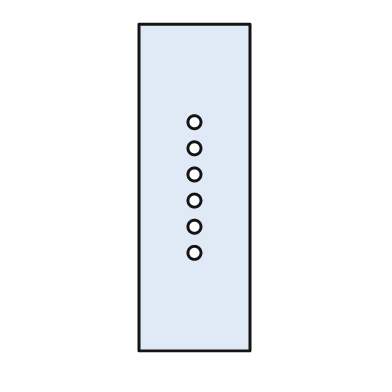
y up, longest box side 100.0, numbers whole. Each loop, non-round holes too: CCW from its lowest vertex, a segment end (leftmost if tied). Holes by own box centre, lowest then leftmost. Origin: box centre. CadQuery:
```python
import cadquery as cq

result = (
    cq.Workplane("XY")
    .moveTo(-17.0, -50.0)
    .lineTo(17.0, -50.0)
    .lineTo(17.0, 50.0)
    .lineTo(-17.0, 50.0)
    .close()
    .moveTo(0.0, -20.0)
    .circle(2.0)
    .moveTo(0.0, -12.0)
    .circle(2.0)
    .moveTo(0.0, -4.0)
    .circle(2.0)
    .moveTo(0.0, 4.0)
    .circle(2.0)
    .moveTo(0.0, 12.0)
    .circle(2.0)
    .moveTo(0.0, 20.0)
    .circle(2.0)
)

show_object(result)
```